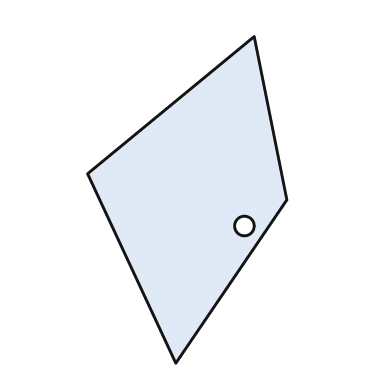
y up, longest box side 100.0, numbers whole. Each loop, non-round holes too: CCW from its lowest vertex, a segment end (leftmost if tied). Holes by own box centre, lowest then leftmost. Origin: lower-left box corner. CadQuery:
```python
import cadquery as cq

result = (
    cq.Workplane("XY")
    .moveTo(27.0, 0.0)
    .lineTo(61.0, 50.0)
    .lineTo(51.0, 100.0)
    .lineTo(0.0, 58.0)
    .close()
    .moveTo(48.0, 42.0)
    .circle(3.0)
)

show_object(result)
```